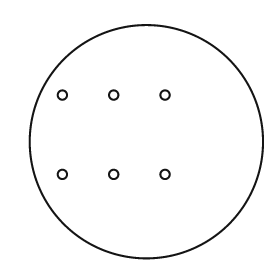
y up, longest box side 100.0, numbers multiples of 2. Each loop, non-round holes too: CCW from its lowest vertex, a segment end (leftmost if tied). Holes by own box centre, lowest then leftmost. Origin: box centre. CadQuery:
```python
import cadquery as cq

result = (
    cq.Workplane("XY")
    .moveTo(0.0, 0.0)
    .circle(50.0)
    .moveTo(-36.0, -14.0)
    .circle(2.0)
    .moveTo(-14.0, -14.0)
    .circle(2.0)
    .moveTo(8.0, -14.0)
    .circle(2.0)
    .moveTo(-36.0, 20.0)
    .circle(2.0)
    .moveTo(-14.0, 20.0)
    .circle(2.0)
    .moveTo(8.0, 20.0)
    .circle(2.0)
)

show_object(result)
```